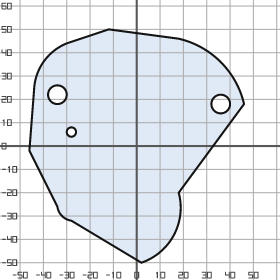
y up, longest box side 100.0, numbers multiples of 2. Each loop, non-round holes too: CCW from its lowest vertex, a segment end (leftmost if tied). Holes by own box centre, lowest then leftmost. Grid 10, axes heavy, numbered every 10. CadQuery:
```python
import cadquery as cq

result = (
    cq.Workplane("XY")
    .moveTo(2.0, -50.0)
    .threePointArc((16.0, -38.0), (18.0, -20.0))
    .lineTo(46.0, 18.0)
    .threePointArc((36.0, 36.0), (18.0, 46.0))
    .lineTo(-12.0, 50.0)
    .lineTo(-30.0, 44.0)
    .threePointArc((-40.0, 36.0), (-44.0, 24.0))
    .lineTo(-46.0, -2.0)
    .lineTo(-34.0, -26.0)
    .threePointArc((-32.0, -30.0), (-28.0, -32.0))
    .close()
    .moveTo(-28.0, 6.0)
    .circle(2.0)
    .moveTo(36.0, 18.0)
    .circle(4.0)
    .moveTo(-34.0, 22.0)
    .circle(4.0)
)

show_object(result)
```